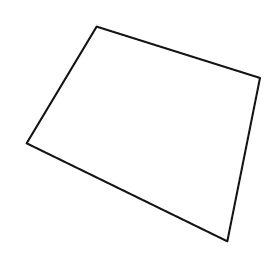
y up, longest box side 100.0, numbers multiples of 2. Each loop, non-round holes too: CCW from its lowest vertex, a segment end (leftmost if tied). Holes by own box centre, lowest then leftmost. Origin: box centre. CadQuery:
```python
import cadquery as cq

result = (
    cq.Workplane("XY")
    .moveTo(36.0, -46.0)
    .lineTo(50.0, 24.0)
    .lineTo(-20.0, 46.0)
    .lineTo(-50.0, -4.0)
    .close()
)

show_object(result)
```